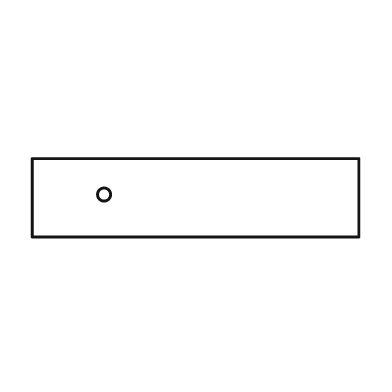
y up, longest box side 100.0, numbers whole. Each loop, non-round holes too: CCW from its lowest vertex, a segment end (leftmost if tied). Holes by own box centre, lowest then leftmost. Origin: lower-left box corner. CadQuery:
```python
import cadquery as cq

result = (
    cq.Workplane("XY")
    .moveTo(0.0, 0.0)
    .lineTo(100.0, 0.0)
    .lineTo(100.0, 24.0)
    .lineTo(0.0, 24.0)
    .close()
    .moveTo(22.0, 13.0)
    .circle(2.0)
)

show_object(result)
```